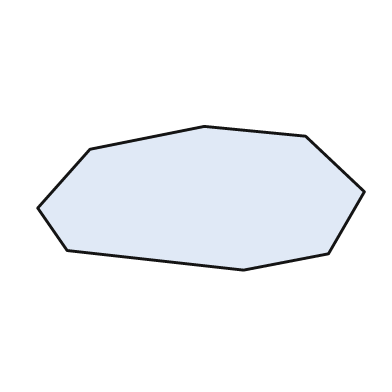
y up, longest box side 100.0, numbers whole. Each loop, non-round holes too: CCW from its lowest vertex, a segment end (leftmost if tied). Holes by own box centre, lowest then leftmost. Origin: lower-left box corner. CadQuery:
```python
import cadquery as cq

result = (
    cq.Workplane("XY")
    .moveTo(63.0, 0.0)
    .lineTo(89.0, 5.0)
    .lineTo(100.0, 24.0)
    .lineTo(82.0, 41.0)
    .lineTo(51.0, 44.0)
    .lineTo(16.0, 37.0)
    .lineTo(0.0, 19.0)
    .lineTo(9.0, 6.0)
    .close()
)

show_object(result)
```